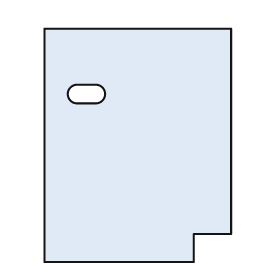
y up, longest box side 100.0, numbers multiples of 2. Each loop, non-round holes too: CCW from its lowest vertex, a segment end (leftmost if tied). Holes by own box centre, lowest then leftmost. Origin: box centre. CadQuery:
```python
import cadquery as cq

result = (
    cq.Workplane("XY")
    .moveTo(-40.0, -50.0)
    .lineTo(24.0, -50.0)
    .lineTo(24.0, -38.0)
    .lineTo(40.0, -38.0)
    .lineTo(40.0, 50.0)
    .lineTo(-40.0, 50.0)
    .close()
    .moveTo(-26.0, 18.0)
    .lineTo(-18.0, 18.0)
    .threePointArc((-14.0, 22.0), (-18.0, 26.0))
    .lineTo(-26.0, 26.0)
    .threePointArc((-30.0, 22.0), (-26.0, 18.0))
    .close()
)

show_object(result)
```